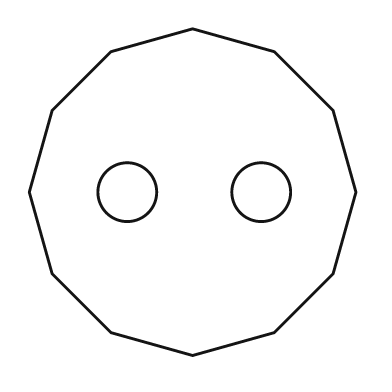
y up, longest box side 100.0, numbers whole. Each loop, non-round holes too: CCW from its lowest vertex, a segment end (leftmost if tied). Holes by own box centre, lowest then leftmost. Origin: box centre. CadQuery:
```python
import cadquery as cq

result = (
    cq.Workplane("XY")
    .moveTo(0.0, -50.0)
    .lineTo(25.0, -43.0)
    .lineTo(43.0, -25.0)
    .lineTo(50.0, 0.0)
    .lineTo(43.0, 25.0)
    .lineTo(25.0, 43.0)
    .lineTo(0.0, 50.0)
    .lineTo(-25.0, 43.0)
    .lineTo(-43.0, 25.0)
    .lineTo(-50.0, 0.0)
    .lineTo(-43.0, -25.0)
    .lineTo(-25.0, -43.0)
    .close()
    .moveTo(-20.0, 0.0)
    .circle(9.0)
    .moveTo(21.0, 0.0)
    .circle(9.0)
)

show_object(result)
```